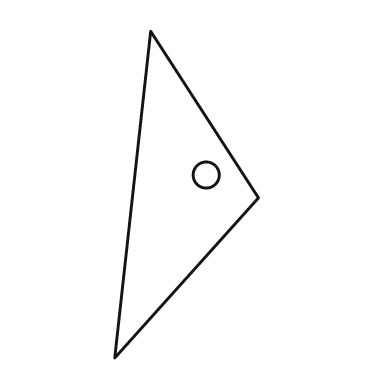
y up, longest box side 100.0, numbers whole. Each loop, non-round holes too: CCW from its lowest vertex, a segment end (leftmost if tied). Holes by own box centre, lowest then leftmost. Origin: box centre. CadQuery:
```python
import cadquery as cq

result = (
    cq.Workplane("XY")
    .moveTo(-22.0, -50.0)
    .lineTo(22.0, -1.0)
    .lineTo(-11.0, 50.0)
    .close()
    .moveTo(6.0, 6.0)
    .circle(4.0)
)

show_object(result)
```